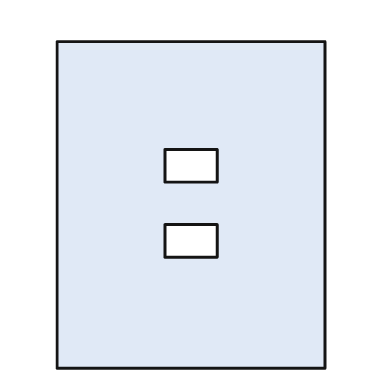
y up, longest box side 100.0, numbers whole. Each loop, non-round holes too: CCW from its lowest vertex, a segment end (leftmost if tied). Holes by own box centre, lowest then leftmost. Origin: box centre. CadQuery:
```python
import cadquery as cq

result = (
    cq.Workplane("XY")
    .moveTo(-41.0, -50.0)
    .lineTo(41.0, -50.0)
    .lineTo(41.0, 50.0)
    .lineTo(-41.0, 50.0)
    .close()
    .moveTo(-8.0, -16.0)
    .lineTo(8.0, -16.0)
    .lineTo(8.0, -6.0)
    .lineTo(-8.0, -6.0)
    .close()
    .moveTo(-8.0, 7.0)
    .lineTo(8.0, 7.0)
    .lineTo(8.0, 17.0)
    .lineTo(-8.0, 17.0)
    .close()
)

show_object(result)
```